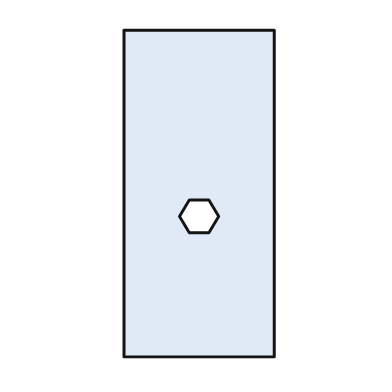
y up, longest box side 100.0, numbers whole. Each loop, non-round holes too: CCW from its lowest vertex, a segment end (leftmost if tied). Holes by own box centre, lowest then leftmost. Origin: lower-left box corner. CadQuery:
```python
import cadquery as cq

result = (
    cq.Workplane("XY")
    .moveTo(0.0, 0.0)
    .lineTo(46.0, 0.0)
    .lineTo(46.0, 100.0)
    .lineTo(0.0, 100.0)
    .close()
    .moveTo(20.0, 38.0)
    .lineTo(26.0, 38.0)
    .lineTo(29.0, 43.0)
    .lineTo(26.0, 48.0)
    .lineTo(20.0, 48.0)
    .lineTo(17.0, 43.0)
    .close()
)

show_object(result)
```